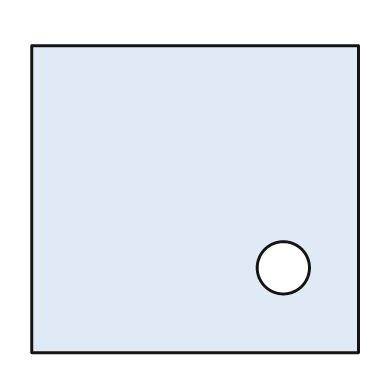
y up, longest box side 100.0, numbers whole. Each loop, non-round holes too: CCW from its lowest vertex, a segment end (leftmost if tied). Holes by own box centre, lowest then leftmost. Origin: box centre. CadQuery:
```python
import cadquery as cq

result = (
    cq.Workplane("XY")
    .moveTo(-50.0, -47.0)
    .lineTo(50.0, -47.0)
    .lineTo(50.0, 47.0)
    .lineTo(-50.0, 47.0)
    .close()
    .moveTo(27.0, -21.0)
    .circle(8.0)
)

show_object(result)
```